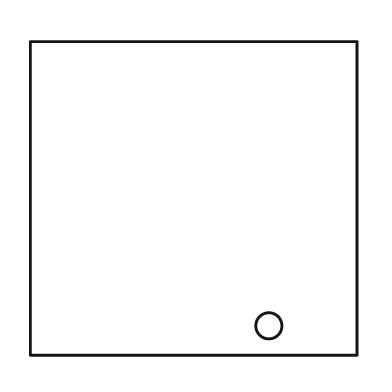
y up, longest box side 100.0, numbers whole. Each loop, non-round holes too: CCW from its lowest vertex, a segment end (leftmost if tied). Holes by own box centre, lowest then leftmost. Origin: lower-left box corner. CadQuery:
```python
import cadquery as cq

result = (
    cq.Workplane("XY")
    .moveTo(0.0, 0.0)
    .lineTo(100.0, 0.0)
    .lineTo(100.0, 96.0)
    .lineTo(0.0, 96.0)
    .close()
    .moveTo(73.0, 9.0)
    .circle(4.0)
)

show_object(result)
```